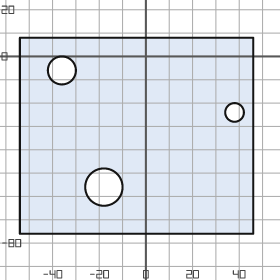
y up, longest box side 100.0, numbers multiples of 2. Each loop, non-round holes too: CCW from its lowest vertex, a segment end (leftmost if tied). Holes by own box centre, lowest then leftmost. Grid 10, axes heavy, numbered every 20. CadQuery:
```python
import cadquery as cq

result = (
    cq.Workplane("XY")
    .moveTo(-54.0, -76.0)
    .lineTo(46.0, -76.0)
    .lineTo(46.0, 8.0)
    .lineTo(-54.0, 8.0)
    .close()
    .moveTo(-18.0, -56.0)
    .circle(8.0)
    .moveTo(38.0, -24.0)
    .circle(4.0)
    .moveTo(-36.0, -6.0)
    .circle(6.0)
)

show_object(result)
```